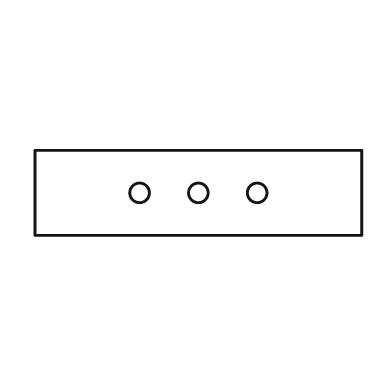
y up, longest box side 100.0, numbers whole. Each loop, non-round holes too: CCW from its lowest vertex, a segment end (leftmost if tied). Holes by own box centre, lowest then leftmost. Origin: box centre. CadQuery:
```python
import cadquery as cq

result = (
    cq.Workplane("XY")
    .moveTo(-50.0, -13.0)
    .lineTo(50.0, -13.0)
    .lineTo(50.0, 13.0)
    .lineTo(-50.0, 13.0)
    .close()
    .moveTo(-18.0, 0.0)
    .circle(3.0)
    .moveTo(0.0, 0.0)
    .circle(3.0)
    .moveTo(18.0, 0.0)
    .circle(3.0)
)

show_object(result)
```